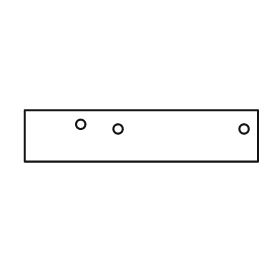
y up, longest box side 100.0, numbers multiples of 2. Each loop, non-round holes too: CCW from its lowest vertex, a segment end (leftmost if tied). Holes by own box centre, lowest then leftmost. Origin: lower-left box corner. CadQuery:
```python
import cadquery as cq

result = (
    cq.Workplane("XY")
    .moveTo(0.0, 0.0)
    .lineTo(100.0, 0.0)
    .lineTo(100.0, 22.0)
    .lineTo(0.0, 22.0)
    .close()
    .moveTo(40.0, 14.0)
    .circle(2.0)
    .moveTo(94.0, 14.0)
    .circle(2.0)
    .moveTo(24.0, 16.0)
    .circle(2.0)
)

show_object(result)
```